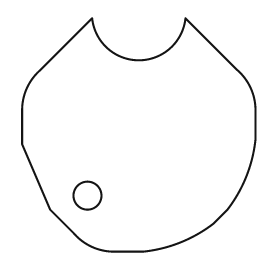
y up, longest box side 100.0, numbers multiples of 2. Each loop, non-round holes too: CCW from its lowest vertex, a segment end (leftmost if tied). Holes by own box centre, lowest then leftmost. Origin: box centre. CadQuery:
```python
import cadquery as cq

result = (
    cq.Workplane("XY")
    .moveTo(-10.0, -50.0)
    .lineTo(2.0, -50.0)
    .threePointArc((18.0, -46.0), (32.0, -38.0))
    .lineTo(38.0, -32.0)
    .threePointArc((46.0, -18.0), (50.0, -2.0))
    .lineTo(50.0, 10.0)
    .threePointArc((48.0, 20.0), (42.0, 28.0))
    .lineTo(20.0, 50.0)
    .threePointArc((0.0, 32.0), (-20.0, 50.0))
    .lineTo(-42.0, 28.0)
    .threePointArc((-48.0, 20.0), (-50.0, 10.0))
    .lineTo(-50.0, -4.0)
    .lineTo(-38.0, -32.0)
    .lineTo(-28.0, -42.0)
    .threePointArc((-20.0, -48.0), (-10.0, -50.0))
    .close()
    .moveTo(-22.0, -26.0)
    .circle(6.0)
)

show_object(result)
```